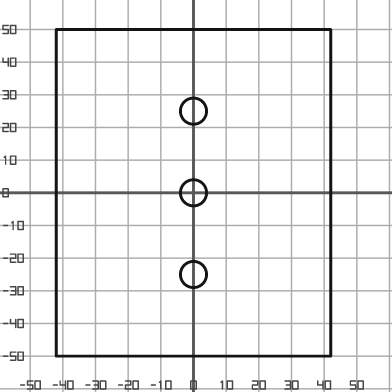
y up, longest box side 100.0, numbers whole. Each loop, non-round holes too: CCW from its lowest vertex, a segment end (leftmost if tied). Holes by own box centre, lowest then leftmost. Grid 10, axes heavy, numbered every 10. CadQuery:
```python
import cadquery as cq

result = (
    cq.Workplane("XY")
    .moveTo(-42.0, -50.0)
    .lineTo(42.0, -50.0)
    .lineTo(42.0, 50.0)
    .lineTo(-42.0, 50.0)
    .close()
    .moveTo(0.0, -25.0)
    .circle(4.0)
    .moveTo(0.0, 0.0)
    .circle(4.0)
    .moveTo(0.0, 25.0)
    .circle(4.0)
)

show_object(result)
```